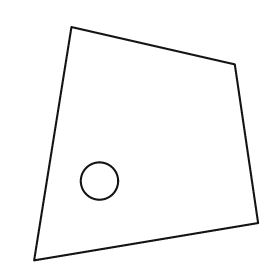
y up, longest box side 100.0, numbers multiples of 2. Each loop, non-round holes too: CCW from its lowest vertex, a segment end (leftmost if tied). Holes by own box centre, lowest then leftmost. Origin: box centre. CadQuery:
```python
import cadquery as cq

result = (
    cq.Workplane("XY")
    .moveTo(-48.0, -50.0)
    .lineTo(48.0, -34.0)
    .lineTo(38.0, 34.0)
    .lineTo(-32.0, 50.0)
    .close()
    .moveTo(-20.0, -16.0)
    .circle(8.0)
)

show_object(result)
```